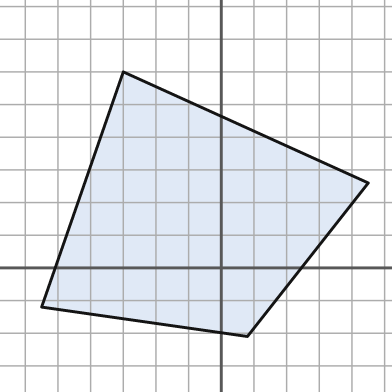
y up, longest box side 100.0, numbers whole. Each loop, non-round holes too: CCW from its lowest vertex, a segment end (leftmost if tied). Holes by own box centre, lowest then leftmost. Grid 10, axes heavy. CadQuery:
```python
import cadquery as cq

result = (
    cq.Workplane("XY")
    .moveTo(8.0, -21.0)
    .lineTo(45.0, 26.0)
    .lineTo(-30.0, 60.0)
    .lineTo(-55.0, -12.0)
    .close()
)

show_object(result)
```